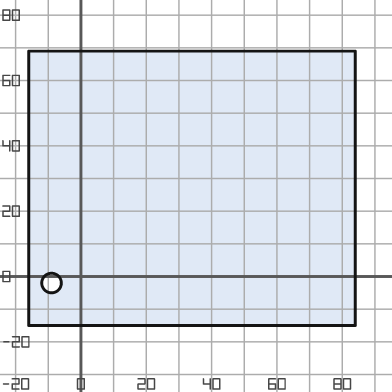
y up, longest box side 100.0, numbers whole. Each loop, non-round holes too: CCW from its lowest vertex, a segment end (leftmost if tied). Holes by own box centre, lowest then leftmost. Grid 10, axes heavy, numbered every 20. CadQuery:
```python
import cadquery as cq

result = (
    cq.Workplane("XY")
    .moveTo(-16.0, -15.0)
    .lineTo(84.0, -15.0)
    .lineTo(84.0, 69.0)
    .lineTo(-16.0, 69.0)
    .close()
    .moveTo(-9.0, -2.0)
    .circle(3.0)
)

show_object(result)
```